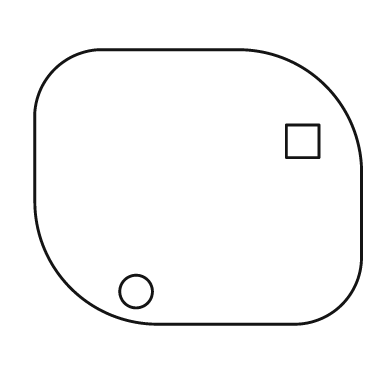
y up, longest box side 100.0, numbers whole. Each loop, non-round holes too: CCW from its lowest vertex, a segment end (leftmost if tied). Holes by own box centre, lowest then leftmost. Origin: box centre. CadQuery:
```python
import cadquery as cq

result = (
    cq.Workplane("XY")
    .moveTo(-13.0, -42.0)
    .lineTo(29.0, -42.0)
    .threePointArc((44.0, -36.0), (50.0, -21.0))
    .lineTo(50.0, 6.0)
    .threePointArc((39.0, 31.0), (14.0, 42.0))
    .lineTo(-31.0, 42.0)
    .threePointArc((-44.0, 36.0), (-50.0, 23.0))
    .lineTo(-50.0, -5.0)
    .threePointArc((-39.0, -31.0), (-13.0, -42.0))
    .close()
    .moveTo(-19.0, -32.0)
    .circle(5.0)
    .moveTo(27.0, 9.0)
    .lineTo(37.0, 9.0)
    .lineTo(37.0, 19.0)
    .lineTo(27.0, 19.0)
    .close()
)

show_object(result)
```